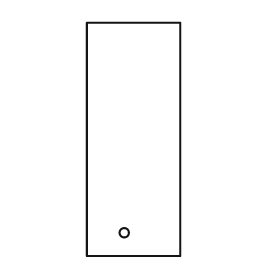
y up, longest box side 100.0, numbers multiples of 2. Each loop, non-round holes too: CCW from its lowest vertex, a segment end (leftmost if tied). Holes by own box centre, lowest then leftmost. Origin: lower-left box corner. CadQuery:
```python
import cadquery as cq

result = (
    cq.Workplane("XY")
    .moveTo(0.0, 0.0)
    .lineTo(40.0, 0.0)
    .lineTo(40.0, 100.0)
    .lineTo(0.0, 100.0)
    .close()
    .moveTo(16.0, 10.0)
    .circle(2.0)
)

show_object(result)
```